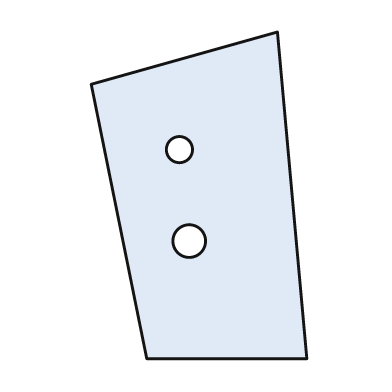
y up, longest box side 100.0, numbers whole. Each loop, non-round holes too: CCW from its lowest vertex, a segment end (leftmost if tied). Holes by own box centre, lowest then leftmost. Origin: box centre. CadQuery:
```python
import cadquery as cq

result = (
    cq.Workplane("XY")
    .moveTo(-16.0, -50.0)
    .lineTo(33.0, -50.0)
    .lineTo(24.0, 50.0)
    .lineTo(-33.0, 34.0)
    .close()
    .moveTo(-3.0, -14.0)
    .circle(5.0)
    .moveTo(-6.0, 14.0)
    .circle(4.0)
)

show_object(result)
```